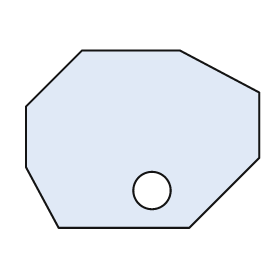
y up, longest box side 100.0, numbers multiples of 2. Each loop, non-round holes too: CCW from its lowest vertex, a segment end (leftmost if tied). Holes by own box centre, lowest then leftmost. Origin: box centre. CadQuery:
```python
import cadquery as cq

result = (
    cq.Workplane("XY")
    .moveTo(-36.0, -38.0)
    .lineTo(20.0, -38.0)
    .lineTo(50.0, -8.0)
    .lineTo(50.0, 20.0)
    .lineTo(16.0, 38.0)
    .lineTo(-26.0, 38.0)
    .lineTo(-50.0, 14.0)
    .lineTo(-50.0, -12.0)
    .close()
    .moveTo(4.0, -22.0)
    .circle(8.0)
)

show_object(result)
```